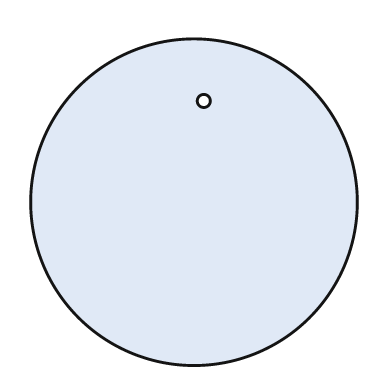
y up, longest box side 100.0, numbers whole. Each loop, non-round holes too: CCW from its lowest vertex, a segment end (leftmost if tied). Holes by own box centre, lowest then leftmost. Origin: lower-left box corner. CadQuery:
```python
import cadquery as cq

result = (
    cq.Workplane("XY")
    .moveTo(50.0, 50.0)
    .circle(50.0)
    .moveTo(53.0, 81.0)
    .circle(2.0)
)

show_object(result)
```